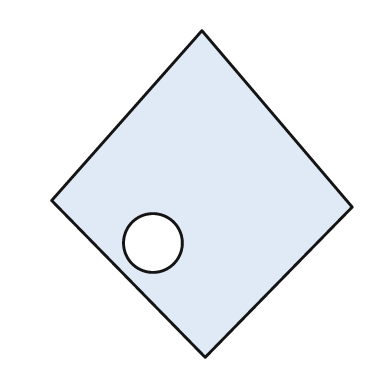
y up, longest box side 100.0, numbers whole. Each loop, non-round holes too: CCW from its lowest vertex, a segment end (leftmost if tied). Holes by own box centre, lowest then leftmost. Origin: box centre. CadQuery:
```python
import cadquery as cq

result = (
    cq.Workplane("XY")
    .moveTo(1.0, -50.0)
    .lineTo(46.0, -4.0)
    .lineTo(0.0, 50.0)
    .lineTo(-46.0, -2.0)
    .close()
    .moveTo(-15.0, -15.0)
    .circle(9.0)
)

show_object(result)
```